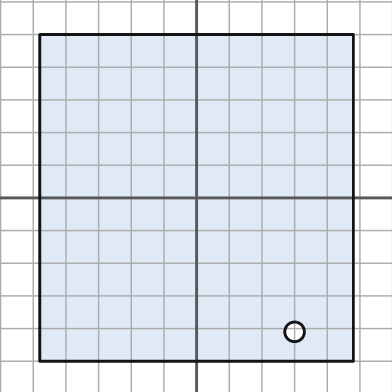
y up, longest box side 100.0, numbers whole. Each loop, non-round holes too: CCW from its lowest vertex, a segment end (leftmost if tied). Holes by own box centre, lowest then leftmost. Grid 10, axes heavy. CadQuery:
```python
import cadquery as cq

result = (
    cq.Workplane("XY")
    .moveTo(-48.0, -50.0)
    .lineTo(48.0, -50.0)
    .lineTo(48.0, 50.0)
    .lineTo(-48.0, 50.0)
    .close()
    .moveTo(30.0, -41.0)
    .circle(3.0)
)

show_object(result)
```